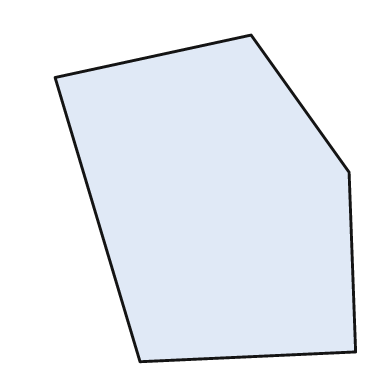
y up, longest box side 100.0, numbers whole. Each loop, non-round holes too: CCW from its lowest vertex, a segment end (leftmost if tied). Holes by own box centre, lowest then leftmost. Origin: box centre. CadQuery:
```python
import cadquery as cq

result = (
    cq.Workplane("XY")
    .moveTo(-20.0, -50.0)
    .lineTo(46.0, -47.0)
    .lineTo(44.0, 8.0)
    .lineTo(14.0, 50.0)
    .lineTo(-46.0, 37.0)
    .close()
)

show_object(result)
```